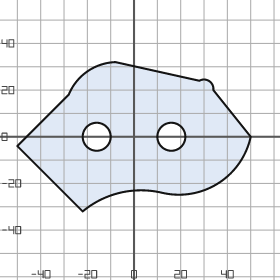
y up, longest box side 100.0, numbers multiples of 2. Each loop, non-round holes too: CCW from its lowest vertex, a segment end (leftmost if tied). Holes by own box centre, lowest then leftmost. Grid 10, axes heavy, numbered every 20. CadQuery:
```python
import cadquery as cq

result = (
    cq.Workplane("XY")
    .moveTo(-22.0, -32.0)
    .threePointArc((-6.0, -24.0), (12.0, -24.0))
    .threePointArc((36.0, -20.0), (50.0, 0.0))
    .lineTo(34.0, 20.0)
    .threePointArc((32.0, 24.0), (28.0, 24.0))
    .lineTo(-8.0, 32.0)
    .threePointArc((-20.0, 28.0), (-28.0, 18.0))
    .lineTo(-50.0, -4.0)
    .close()
    .moveTo(-16.0, 0.0)
    .circle(6.0)
    .moveTo(16.0, 0.0)
    .circle(6.0)
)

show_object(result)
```